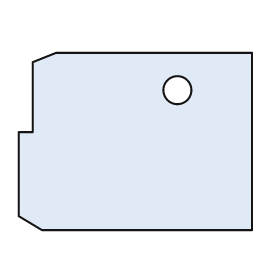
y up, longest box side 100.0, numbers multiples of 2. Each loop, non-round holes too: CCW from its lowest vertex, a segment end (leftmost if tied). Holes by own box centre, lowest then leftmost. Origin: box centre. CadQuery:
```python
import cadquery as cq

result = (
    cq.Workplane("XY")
    .moveTo(-40.0, -38.0)
    .lineTo(50.0, -38.0)
    .lineTo(50.0, 38.0)
    .lineTo(-34.0, 38.0)
    .lineTo(-44.0, 34.0)
    .lineTo(-44.0, 4.0)
    .lineTo(-50.0, 4.0)
    .lineTo(-50.0, -32.0)
    .close()
    .moveTo(18.0, 22.0)
    .circle(6.0)
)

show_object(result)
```